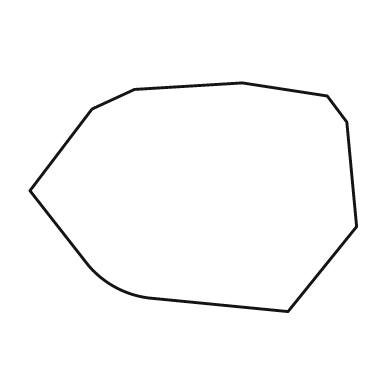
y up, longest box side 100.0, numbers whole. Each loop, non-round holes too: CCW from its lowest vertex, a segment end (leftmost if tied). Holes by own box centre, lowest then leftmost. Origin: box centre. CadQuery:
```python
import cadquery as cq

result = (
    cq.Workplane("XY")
    .moveTo(29.0, -35.0)
    .lineTo(50.0, -9.0)
    .lineTo(47.0, 23.0)
    .lineTo(41.0, 31.0)
    .lineTo(15.0, 35.0)
    .lineTo(-18.0, 33.0)
    .lineTo(-31.0, 27.0)
    .lineTo(-50.0, 2.0)
    .lineTo(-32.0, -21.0)
    .threePointArc((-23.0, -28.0), (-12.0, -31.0))
    .close()
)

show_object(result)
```